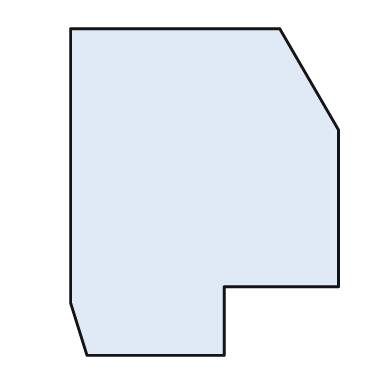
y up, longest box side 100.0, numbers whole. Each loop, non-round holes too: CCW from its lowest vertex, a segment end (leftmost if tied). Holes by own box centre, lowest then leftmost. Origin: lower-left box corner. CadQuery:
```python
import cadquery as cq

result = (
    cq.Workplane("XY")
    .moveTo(5.0, 0.0)
    .lineTo(47.0, 0.0)
    .lineTo(47.0, 21.0)
    .lineTo(82.0, 21.0)
    .lineTo(82.0, 69.0)
    .lineTo(64.0, 100.0)
    .lineTo(0.0, 100.0)
    .lineTo(0.0, 16.0)
    .close()
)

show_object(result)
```